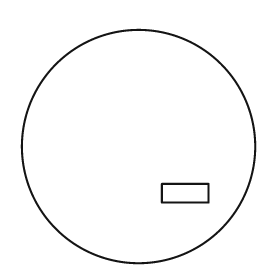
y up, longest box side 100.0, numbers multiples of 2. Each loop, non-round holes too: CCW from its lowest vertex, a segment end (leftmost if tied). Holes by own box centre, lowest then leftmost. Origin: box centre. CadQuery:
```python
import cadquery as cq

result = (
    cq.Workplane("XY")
    .moveTo(0.0, 0.0)
    .circle(50.0)
    .moveTo(10.0, -24.0)
    .lineTo(30.0, -24.0)
    .lineTo(30.0, -16.0)
    .lineTo(10.0, -16.0)
    .close()
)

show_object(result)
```